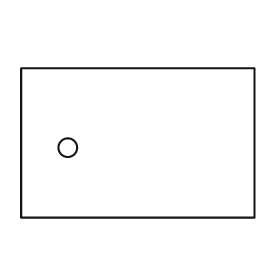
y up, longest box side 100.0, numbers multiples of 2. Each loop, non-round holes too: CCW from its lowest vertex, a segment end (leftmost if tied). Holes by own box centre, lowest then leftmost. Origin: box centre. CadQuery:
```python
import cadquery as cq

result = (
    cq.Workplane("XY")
    .moveTo(-50.0, -32.0)
    .lineTo(50.0, -32.0)
    .lineTo(50.0, 32.0)
    .lineTo(-50.0, 32.0)
    .close()
    .moveTo(-30.0, -2.0)
    .circle(4.0)
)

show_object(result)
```